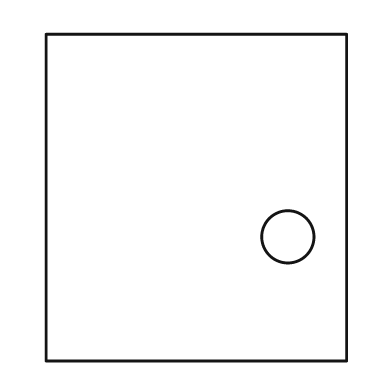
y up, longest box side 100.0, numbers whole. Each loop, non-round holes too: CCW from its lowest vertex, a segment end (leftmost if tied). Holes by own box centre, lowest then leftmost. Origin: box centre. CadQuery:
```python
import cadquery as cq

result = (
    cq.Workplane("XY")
    .moveTo(-46.0, -50.0)
    .lineTo(46.0, -50.0)
    .lineTo(46.0, 50.0)
    .lineTo(-46.0, 50.0)
    .close()
    .moveTo(28.0, -12.0)
    .circle(8.0)
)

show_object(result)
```